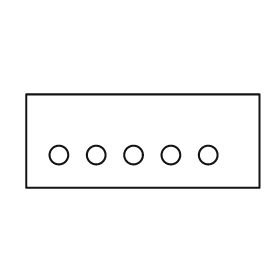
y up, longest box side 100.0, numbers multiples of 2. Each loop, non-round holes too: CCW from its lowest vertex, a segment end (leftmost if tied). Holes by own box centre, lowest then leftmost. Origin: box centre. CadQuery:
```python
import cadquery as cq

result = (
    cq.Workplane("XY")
    .moveTo(-50.0, -20.0)
    .lineTo(50.0, -20.0)
    .lineTo(50.0, 20.0)
    .lineTo(-50.0, 20.0)
    .close()
    .moveTo(-36.0, -6.0)
    .circle(4.0)
    .moveTo(-20.0, -6.0)
    .circle(4.0)
    .moveTo(-4.0, -6.0)
    .circle(4.0)
    .moveTo(12.0, -6.0)
    .circle(4.0)
    .moveTo(28.0, -6.0)
    .circle(4.0)
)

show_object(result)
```